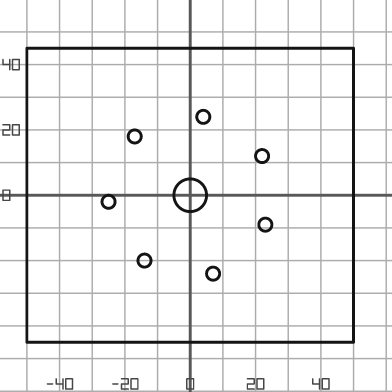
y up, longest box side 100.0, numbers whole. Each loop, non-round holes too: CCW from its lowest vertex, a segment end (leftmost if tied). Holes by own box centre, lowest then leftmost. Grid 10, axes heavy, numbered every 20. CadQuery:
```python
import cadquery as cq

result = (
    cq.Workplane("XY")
    .moveTo(-50.0, -45.0)
    .lineTo(50.0, -45.0)
    .lineTo(50.0, 45.0)
    .lineTo(-50.0, 45.0)
    .close()
    .moveTo(7.0, -24.0)
    .circle(2.0)
    .moveTo(-14.0, -20.0)
    .circle(2.0)
    .moveTo(23.0, -9.0)
    .circle(2.0)
    .moveTo(-25.0, -2.0)
    .circle(2.0)
    .moveTo(0.0, 0.0)
    .circle(5.0)
    .moveTo(22.0, 12.0)
    .circle(2.0)
    .moveTo(-17.0, 18.0)
    .circle(2.0)
    .moveTo(4.0, 24.0)
    .circle(2.0)
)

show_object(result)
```